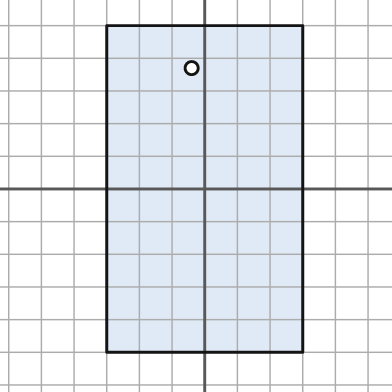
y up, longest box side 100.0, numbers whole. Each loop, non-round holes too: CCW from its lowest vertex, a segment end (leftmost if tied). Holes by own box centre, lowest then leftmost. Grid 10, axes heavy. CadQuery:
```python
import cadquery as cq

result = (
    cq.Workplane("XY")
    .moveTo(-30.0, -50.0)
    .lineTo(30.0, -50.0)
    .lineTo(30.0, 50.0)
    .lineTo(-30.0, 50.0)
    .close()
    .moveTo(-4.0, 37.0)
    .circle(2.0)
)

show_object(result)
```